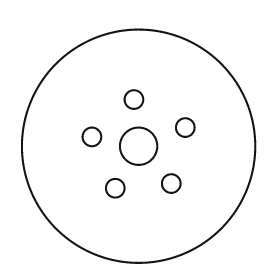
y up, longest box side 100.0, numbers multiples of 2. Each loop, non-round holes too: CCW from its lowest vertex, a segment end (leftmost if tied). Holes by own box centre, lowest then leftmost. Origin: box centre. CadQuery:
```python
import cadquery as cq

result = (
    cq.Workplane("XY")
    .moveTo(0.0, 0.0)
    .circle(50.0)
    .moveTo(-10.0, -18.0)
    .circle(4.0)
    .moveTo(14.0, -16.0)
    .circle(4.0)
    .moveTo(0.0, 0.0)
    .circle(8.0)
    .moveTo(-20.0, 4.0)
    .circle(4.0)
    .moveTo(20.0, 8.0)
    .circle(4.0)
    .moveTo(-2.0, 20.0)
    .circle(4.0)
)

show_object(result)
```